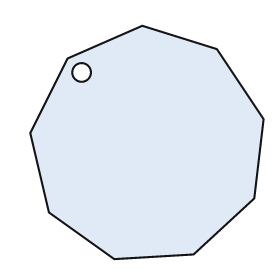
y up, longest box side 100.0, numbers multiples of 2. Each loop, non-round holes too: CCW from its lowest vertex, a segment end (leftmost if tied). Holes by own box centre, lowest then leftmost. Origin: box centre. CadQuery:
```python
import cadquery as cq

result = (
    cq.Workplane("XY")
    .moveTo(-14.0, -50.0)
    .lineTo(20.0, -48.0)
    .lineTo(46.0, -24.0)
    .lineTo(50.0, 10.0)
    .lineTo(30.0, 40.0)
    .lineTo(-2.0, 50.0)
    .lineTo(-34.0, 36.0)
    .lineTo(-50.0, 4.0)
    .lineTo(-42.0, -30.0)
    .close()
    .moveTo(-28.0, 30.0)
    .circle(4.0)
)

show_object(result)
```